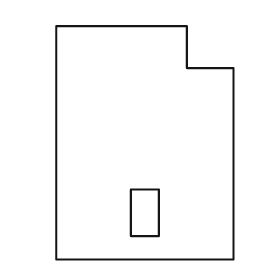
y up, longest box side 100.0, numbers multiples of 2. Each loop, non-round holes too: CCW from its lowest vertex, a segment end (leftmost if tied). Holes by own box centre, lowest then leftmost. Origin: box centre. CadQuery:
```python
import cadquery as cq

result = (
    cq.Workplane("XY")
    .moveTo(-38.0, -50.0)
    .lineTo(38.0, -50.0)
    .lineTo(38.0, 32.0)
    .lineTo(18.0, 32.0)
    .lineTo(18.0, 50.0)
    .lineTo(-38.0, 50.0)
    .close()
    .moveTo(-6.0, -40.0)
    .lineTo(6.0, -40.0)
    .lineTo(6.0, -20.0)
    .lineTo(-6.0, -20.0)
    .close()
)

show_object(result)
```